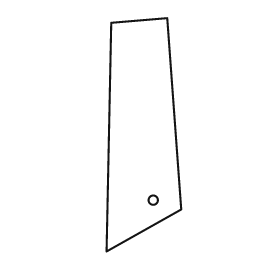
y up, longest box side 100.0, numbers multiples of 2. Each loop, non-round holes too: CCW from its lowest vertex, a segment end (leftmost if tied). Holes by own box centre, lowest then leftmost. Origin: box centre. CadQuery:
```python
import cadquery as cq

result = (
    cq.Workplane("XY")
    .moveTo(-16.0, -50.0)
    .lineTo(16.0, -32.0)
    .lineTo(10.0, 50.0)
    .lineTo(-14.0, 48.0)
    .close()
    .moveTo(4.0, -28.0)
    .circle(2.0)
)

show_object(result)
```